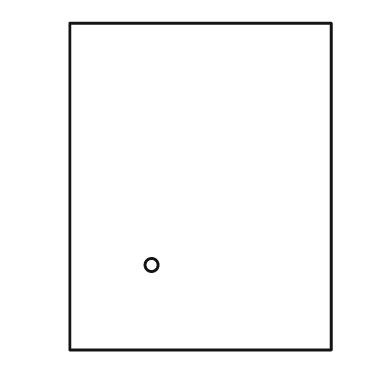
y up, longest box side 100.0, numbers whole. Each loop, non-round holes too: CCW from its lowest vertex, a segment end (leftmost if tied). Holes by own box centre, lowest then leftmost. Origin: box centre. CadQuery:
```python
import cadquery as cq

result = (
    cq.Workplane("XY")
    .moveTo(-40.0, -50.0)
    .lineTo(40.0, -50.0)
    .lineTo(40.0, 50.0)
    .lineTo(-40.0, 50.0)
    .close()
    .moveTo(-15.0, -24.0)
    .circle(2.0)
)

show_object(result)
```